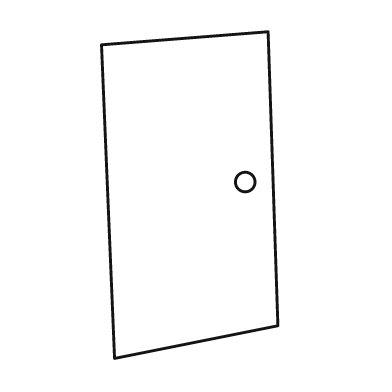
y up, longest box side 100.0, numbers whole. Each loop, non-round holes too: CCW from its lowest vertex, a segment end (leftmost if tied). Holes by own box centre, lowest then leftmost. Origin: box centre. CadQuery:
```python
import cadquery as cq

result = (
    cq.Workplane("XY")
    .moveTo(-23.0, -50.0)
    .lineTo(27.0, -40.0)
    .lineTo(24.0, 50.0)
    .lineTo(-27.0, 46.0)
    .close()
    .moveTo(17.0, 4.0)
    .circle(3.0)
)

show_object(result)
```